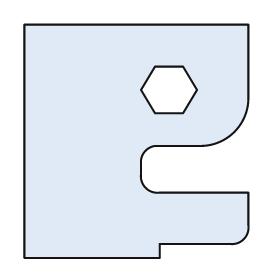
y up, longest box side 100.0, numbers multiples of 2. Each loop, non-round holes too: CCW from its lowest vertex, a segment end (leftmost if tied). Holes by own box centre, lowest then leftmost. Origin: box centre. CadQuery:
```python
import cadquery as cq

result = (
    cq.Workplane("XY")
    .moveTo(-48.0, -50.0)
    .lineTo(10.0, -50.0)
    .lineTo(10.0, -44.0)
    .lineTo(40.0, -44.0)
    .threePointArc((46.0, -42.0), (48.0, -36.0))
    .lineTo(48.0, -22.0)
    .lineTo(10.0, -22.0)
    .threePointArc((4.0, -20.0), (2.0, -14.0))
    .lineTo(2.0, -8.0)
    .threePointArc((4.0, -4.0), (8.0, -2.0))
    .lineTo(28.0, -2.0)
    .threePointArc((42.0, 4.0), (48.0, 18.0))
    .lineTo(48.0, 50.0)
    .lineTo(-48.0, 50.0)
    .close()
    .moveTo(8.0, 12.0)
    .lineTo(20.0, 12.0)
    .lineTo(26.0, 22.0)
    .lineTo(20.0, 32.0)
    .lineTo(8.0, 32.0)
    .lineTo(2.0, 22.0)
    .close()
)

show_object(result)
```